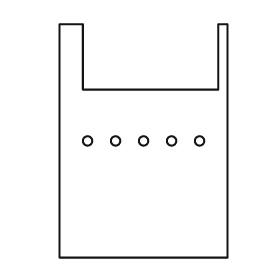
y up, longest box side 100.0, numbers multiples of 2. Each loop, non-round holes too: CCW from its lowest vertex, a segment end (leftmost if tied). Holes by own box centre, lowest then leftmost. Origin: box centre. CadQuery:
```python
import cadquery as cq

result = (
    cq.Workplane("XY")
    .moveTo(-36.0, -50.0)
    .lineTo(36.0, -50.0)
    .lineTo(36.0, 50.0)
    .lineTo(32.0, 50.0)
    .lineTo(32.0, 22.0)
    .lineTo(-26.0, 22.0)
    .lineTo(-26.0, 50.0)
    .lineTo(-36.0, 50.0)
    .close()
    .moveTo(-24.0, 0.0)
    .circle(2.0)
    .moveTo(-12.0, 0.0)
    .circle(2.0)
    .moveTo(0.0, 0.0)
    .circle(2.0)
    .moveTo(12.0, 0.0)
    .circle(2.0)
    .moveTo(24.0, 0.0)
    .circle(2.0)
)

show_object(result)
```